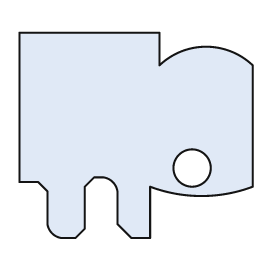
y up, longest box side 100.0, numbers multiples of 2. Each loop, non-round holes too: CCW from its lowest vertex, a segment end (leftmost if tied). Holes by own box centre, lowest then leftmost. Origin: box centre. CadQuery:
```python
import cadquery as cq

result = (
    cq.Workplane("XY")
    .moveTo(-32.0, -44.0)
    .lineTo(-26.0, -44.0)
    .lineTo(-22.0, -40.0)
    .lineTo(-22.0, -22.0)
    .lineTo(-18.0, -18.0)
    .lineTo(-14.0, -18.0)
    .threePointArc((-10.0, -20.0), (-8.0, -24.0))
    .lineTo(-8.0, -38.0)
    .lineTo(-2.0, -44.0)
    .lineTo(6.0, -44.0)
    .lineTo(6.0, -22.0)
    .threePointArc((28.0, -26.0), (50.0, -22.0))
    .lineTo(50.0, 30.0)
    .threePointArc((30.0, 38.0), (10.0, 30.0))
    .lineTo(10.0, 44.0)
    .lineTo(-50.0, 44.0)
    .lineTo(-50.0, -20.0)
    .lineTo(-42.0, -20.0)
    .lineTo(-38.0, -24.0)
    .lineTo(-38.0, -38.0)
    .threePointArc((-36.0, -42.0), (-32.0, -44.0))
    .close()
    .moveTo(24.0, -14.0)
    .circle(8.0)
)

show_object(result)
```